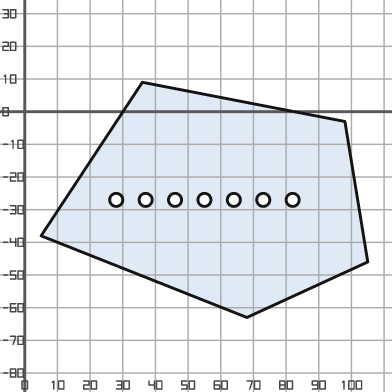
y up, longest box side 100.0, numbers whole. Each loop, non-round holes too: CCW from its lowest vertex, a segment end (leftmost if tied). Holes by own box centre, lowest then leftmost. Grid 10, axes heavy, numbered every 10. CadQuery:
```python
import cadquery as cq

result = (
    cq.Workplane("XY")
    .moveTo(68.0, -63.0)
    .lineTo(105.0, -46.0)
    .lineTo(98.0, -3.0)
    .lineTo(36.0, 9.0)
    .lineTo(5.0, -38.0)
    .close()
    .moveTo(28.0, -27.0)
    .circle(2.0)
    .moveTo(37.0, -27.0)
    .circle(2.0)
    .moveTo(46.0, -27.0)
    .circle(2.0)
    .moveTo(55.0, -27.0)
    .circle(2.0)
    .moveTo(64.0, -27.0)
    .circle(2.0)
    .moveTo(73.0, -27.0)
    .circle(2.0)
    .moveTo(82.0, -27.0)
    .circle(2.0)
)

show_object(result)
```